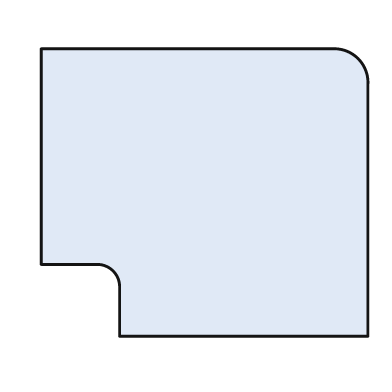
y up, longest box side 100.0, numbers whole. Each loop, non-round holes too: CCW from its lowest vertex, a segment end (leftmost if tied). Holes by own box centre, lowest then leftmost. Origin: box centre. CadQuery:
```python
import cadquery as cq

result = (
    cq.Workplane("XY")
    .moveTo(-26.0, -44.0)
    .lineTo(50.0, -44.0)
    .lineTo(50.0, 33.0)
    .threePointArc((47.0, 41.0), (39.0, 44.0))
    .lineTo(-50.0, 44.0)
    .lineTo(-50.0, -22.0)
    .lineTo(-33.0, -22.0)
    .threePointArc((-28.0, -24.0), (-26.0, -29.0))
    .close()
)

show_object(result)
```